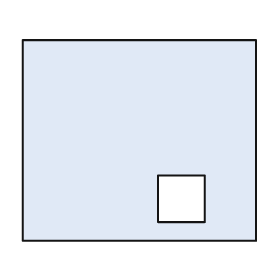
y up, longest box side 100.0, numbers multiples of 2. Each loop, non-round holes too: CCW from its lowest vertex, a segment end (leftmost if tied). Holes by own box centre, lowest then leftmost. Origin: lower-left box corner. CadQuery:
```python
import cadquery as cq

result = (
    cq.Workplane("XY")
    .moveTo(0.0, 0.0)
    .lineTo(100.0, 0.0)
    .lineTo(100.0, 86.0)
    .lineTo(0.0, 86.0)
    .close()
    .moveTo(58.0, 8.0)
    .lineTo(78.0, 8.0)
    .lineTo(78.0, 28.0)
    .lineTo(58.0, 28.0)
    .close()
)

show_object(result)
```